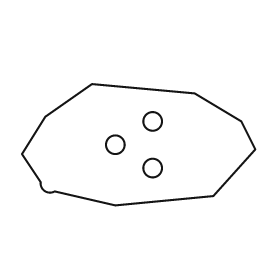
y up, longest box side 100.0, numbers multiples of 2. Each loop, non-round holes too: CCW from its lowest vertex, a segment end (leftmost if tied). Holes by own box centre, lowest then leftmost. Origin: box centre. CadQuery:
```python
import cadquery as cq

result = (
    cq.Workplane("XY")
    .moveTo(-10.0, -26.0)
    .lineTo(32.0, -22.0)
    .lineTo(50.0, -2.0)
    .lineTo(44.0, 10.0)
    .lineTo(24.0, 22.0)
    .lineTo(-20.0, 26.0)
    .lineTo(-40.0, 12.0)
    .lineTo(-50.0, -4.0)
    .lineTo(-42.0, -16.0)
    .threePointArc((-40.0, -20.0), (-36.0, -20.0))
    .close()
    .moveTo(6.0, -10.0)
    .circle(4.0)
    .moveTo(-10.0, 0.0)
    .circle(4.0)
    .moveTo(6.0, 10.0)
    .circle(4.0)
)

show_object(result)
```